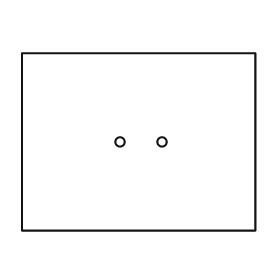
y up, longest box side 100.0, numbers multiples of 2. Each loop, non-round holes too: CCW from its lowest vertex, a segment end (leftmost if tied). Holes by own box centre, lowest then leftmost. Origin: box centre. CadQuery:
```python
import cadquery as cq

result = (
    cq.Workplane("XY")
    .moveTo(-50.0, -38.0)
    .lineTo(50.0, -38.0)
    .lineTo(50.0, 38.0)
    .lineTo(-50.0, 38.0)
    .close()
    .moveTo(-8.0, 0.0)
    .circle(2.0)
    .moveTo(10.0, 0.0)
    .circle(2.0)
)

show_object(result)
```